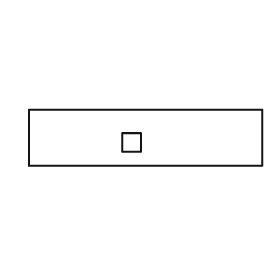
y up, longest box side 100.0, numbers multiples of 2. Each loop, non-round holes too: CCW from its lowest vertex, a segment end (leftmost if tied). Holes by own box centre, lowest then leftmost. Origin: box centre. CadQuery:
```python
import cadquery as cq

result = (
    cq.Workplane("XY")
    .moveTo(-50.0, -12.0)
    .lineTo(50.0, -12.0)
    .lineTo(50.0, 12.0)
    .lineTo(-50.0, 12.0)
    .close()
    .moveTo(-10.0, -6.0)
    .lineTo(-2.0, -6.0)
    .lineTo(-2.0, 2.0)
    .lineTo(-10.0, 2.0)
    .close()
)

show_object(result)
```